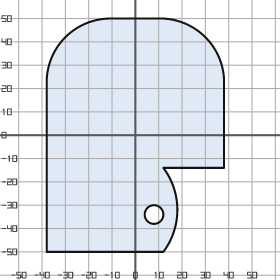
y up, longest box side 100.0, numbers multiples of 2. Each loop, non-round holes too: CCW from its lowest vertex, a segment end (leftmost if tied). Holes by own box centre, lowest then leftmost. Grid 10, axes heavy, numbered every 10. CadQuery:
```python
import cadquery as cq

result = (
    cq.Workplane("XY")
    .moveTo(-38.0, -50.0)
    .lineTo(12.0, -50.0)
    .threePointArc((18.0, -32.0), (12.0, -14.0))
    .lineTo(38.0, -14.0)
    .lineTo(38.0, 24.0)
    .threePointArc((30.0, 42.0), (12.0, 50.0))
    .lineTo(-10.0, 50.0)
    .threePointArc((-30.0, 42.0), (-38.0, 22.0))
    .close()
    .moveTo(8.0, -34.0)
    .circle(4.0)
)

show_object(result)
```